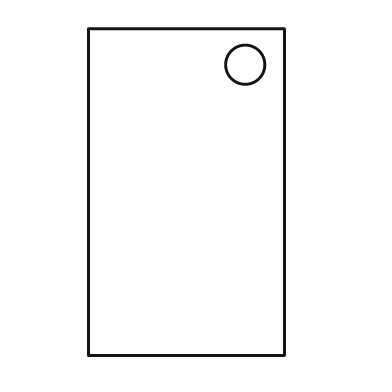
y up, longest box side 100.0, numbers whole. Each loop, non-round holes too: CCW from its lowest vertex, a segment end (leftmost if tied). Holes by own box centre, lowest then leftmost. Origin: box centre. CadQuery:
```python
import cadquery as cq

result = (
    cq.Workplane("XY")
    .moveTo(-30.0, -50.0)
    .lineTo(30.0, -50.0)
    .lineTo(30.0, 50.0)
    .lineTo(-30.0, 50.0)
    .close()
    .moveTo(18.0, 39.0)
    .circle(6.0)
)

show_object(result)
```